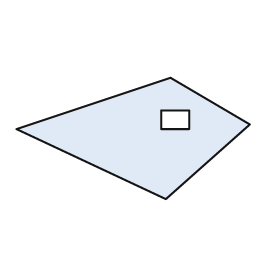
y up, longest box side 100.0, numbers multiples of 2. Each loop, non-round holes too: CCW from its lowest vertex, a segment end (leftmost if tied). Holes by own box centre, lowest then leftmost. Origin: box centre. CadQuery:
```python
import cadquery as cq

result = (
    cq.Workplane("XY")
    .moveTo(14.0, -26.0)
    .lineTo(50.0, 6.0)
    .lineTo(16.0, 26.0)
    .lineTo(-50.0, 4.0)
    .close()
    .moveTo(12.0, 4.0)
    .lineTo(24.0, 4.0)
    .lineTo(24.0, 12.0)
    .lineTo(12.0, 12.0)
    .close()
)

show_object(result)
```